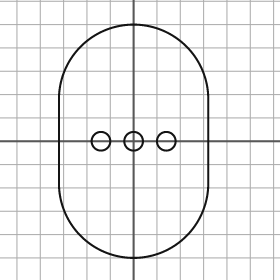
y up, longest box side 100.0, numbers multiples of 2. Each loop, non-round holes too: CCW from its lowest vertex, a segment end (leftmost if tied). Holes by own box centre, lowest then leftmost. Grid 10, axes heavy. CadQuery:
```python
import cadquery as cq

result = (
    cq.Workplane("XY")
    .moveTo(-32.0, -18.0)
    .threePointArc((0.0, -50.0), (32.0, -18.0))
    .lineTo(32.0, 18.0)
    .threePointArc((0.0, 50.0), (-32.0, 18.0))
    .close()
    .moveTo(-14.0, 0.0)
    .circle(4.0)
    .moveTo(0.0, 0.0)
    .circle(4.0)
    .moveTo(14.0, 0.0)
    .circle(4.0)
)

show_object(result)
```